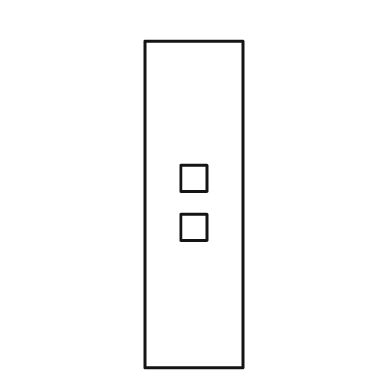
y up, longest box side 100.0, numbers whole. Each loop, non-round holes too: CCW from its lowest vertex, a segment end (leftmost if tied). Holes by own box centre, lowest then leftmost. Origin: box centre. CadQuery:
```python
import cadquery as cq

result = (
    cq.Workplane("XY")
    .moveTo(-15.0, -50.0)
    .lineTo(15.0, -50.0)
    .lineTo(15.0, 50.0)
    .lineTo(-15.0, 50.0)
    .close()
    .moveTo(-4.0, -11.0)
    .lineTo(4.0, -11.0)
    .lineTo(4.0, -3.0)
    .lineTo(-4.0, -3.0)
    .close()
    .moveTo(-4.0, 4.0)
    .lineTo(4.0, 4.0)
    .lineTo(4.0, 12.0)
    .lineTo(-4.0, 12.0)
    .close()
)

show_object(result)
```